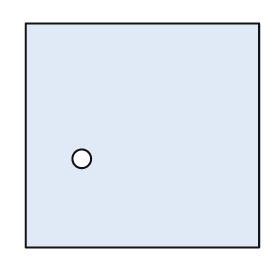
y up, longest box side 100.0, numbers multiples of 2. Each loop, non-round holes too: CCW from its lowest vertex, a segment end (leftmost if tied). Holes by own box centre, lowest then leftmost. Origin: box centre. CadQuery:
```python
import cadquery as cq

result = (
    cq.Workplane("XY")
    .moveTo(-50.0, -48.0)
    .lineTo(50.0, -48.0)
    .lineTo(50.0, 48.0)
    .lineTo(-50.0, 48.0)
    .close()
    .moveTo(-26.0, -10.0)
    .circle(4.0)
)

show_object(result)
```